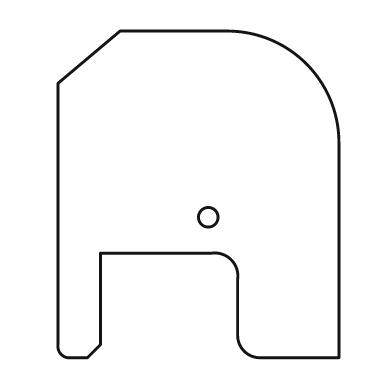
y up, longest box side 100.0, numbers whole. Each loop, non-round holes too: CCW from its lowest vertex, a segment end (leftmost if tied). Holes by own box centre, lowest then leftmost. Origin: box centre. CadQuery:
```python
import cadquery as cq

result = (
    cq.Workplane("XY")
    .moveTo(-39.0, -50.0)
    .lineTo(-34.0, -50.0)
    .lineTo(-30.0, -46.0)
    .lineTo(-30.0, -18.0)
    .lineTo(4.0, -18.0)
    .threePointArc((10.0, -20.0), (12.0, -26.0))
    .lineTo(12.0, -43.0)
    .threePointArc((14.0, -48.0), (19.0, -50.0))
    .lineTo(43.0, -50.0)
    .lineTo(43.0, 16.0)
    .threePointArc((33.0, 40.0), (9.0, 50.0))
    .lineTo(-24.0, 50.0)
    .lineTo(-43.0, 34.0)
    .lineTo(-43.0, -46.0)
    .threePointArc((-42.0, -49.0), (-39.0, -50.0))
    .close()
    .moveTo(3.0, -7.0)
    .circle(3.0)
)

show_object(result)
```